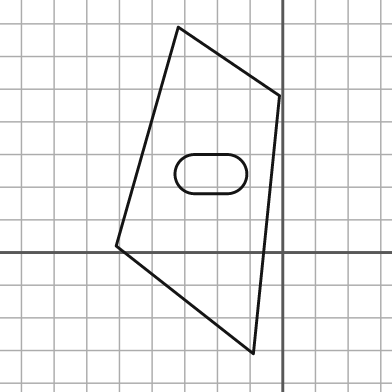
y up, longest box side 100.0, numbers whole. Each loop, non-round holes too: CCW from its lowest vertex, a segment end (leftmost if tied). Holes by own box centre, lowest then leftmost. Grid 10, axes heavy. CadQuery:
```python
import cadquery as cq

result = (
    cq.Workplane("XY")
    .moveTo(-9.0, -31.0)
    .lineTo(-1.0, 48.0)
    .lineTo(-32.0, 69.0)
    .lineTo(-51.0, 2.0)
    .close()
    .moveTo(-27.0, 18.0)
    .lineTo(-17.0, 18.0)
    .threePointArc((-11.0, 24.0), (-17.0, 30.0))
    .lineTo(-27.0, 30.0)
    .threePointArc((-33.0, 24.0), (-27.0, 18.0))
    .close()
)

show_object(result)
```